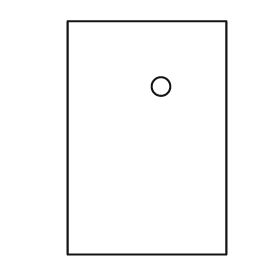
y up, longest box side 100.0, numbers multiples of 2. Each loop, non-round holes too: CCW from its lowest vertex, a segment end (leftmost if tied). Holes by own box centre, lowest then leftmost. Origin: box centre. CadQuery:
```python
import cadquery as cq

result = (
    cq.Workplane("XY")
    .moveTo(-34.0, -50.0)
    .lineTo(34.0, -50.0)
    .lineTo(34.0, 50.0)
    .lineTo(-34.0, 50.0)
    .close()
    .moveTo(6.0, 22.0)
    .circle(4.0)
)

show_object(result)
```